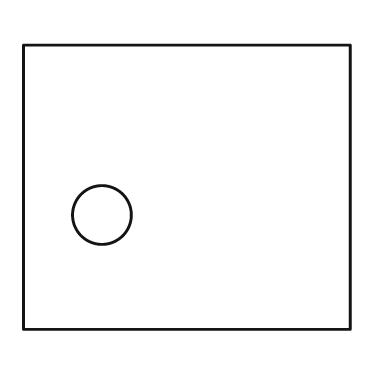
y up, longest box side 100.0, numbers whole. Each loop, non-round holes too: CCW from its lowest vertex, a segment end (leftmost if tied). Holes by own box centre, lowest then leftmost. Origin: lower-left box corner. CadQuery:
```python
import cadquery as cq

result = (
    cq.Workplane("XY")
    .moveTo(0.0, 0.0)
    .lineTo(100.0, 0.0)
    .lineTo(100.0, 87.0)
    .lineTo(0.0, 87.0)
    .close()
    .moveTo(24.0, 35.0)
    .circle(9.0)
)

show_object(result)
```